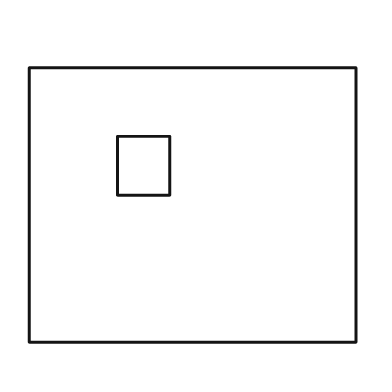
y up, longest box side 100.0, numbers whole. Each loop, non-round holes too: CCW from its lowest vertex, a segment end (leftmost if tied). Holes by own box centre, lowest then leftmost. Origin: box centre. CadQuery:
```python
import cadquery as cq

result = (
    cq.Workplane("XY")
    .moveTo(-50.0, -42.0)
    .lineTo(50.0, -42.0)
    .lineTo(50.0, 42.0)
    .lineTo(-50.0, 42.0)
    .close()
    .moveTo(-23.0, 3.0)
    .lineTo(-7.0, 3.0)
    .lineTo(-7.0, 21.0)
    .lineTo(-23.0, 21.0)
    .close()
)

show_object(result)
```